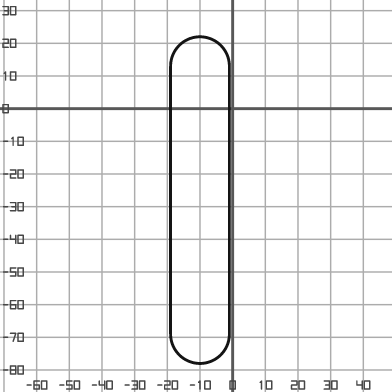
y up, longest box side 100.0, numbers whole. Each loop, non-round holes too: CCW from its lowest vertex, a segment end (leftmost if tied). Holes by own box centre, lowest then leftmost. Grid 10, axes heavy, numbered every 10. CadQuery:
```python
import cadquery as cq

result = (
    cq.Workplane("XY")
    .moveTo(-19.0, -69.0)
    .threePointArc((-10.0, -78.0), (-1.0, -69.0))
    .lineTo(-1.0, 13.0)
    .threePointArc((-10.0, 22.0), (-19.0, 13.0))
    .close()
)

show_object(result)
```